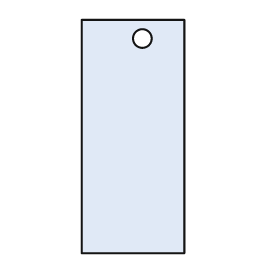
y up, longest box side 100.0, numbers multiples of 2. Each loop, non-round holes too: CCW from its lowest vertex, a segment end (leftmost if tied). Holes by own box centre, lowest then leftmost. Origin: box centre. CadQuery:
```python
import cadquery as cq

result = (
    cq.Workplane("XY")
    .moveTo(-22.0, -50.0)
    .lineTo(22.0, -50.0)
    .lineTo(22.0, 50.0)
    .lineTo(-22.0, 50.0)
    .close()
    .moveTo(4.0, 42.0)
    .circle(4.0)
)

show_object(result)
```